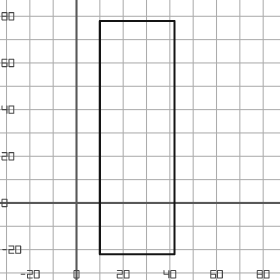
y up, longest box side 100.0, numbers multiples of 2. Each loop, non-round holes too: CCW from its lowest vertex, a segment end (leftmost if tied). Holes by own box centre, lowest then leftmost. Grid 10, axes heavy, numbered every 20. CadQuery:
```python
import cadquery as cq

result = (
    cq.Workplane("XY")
    .moveTo(10.0, -22.0)
    .lineTo(42.0, -22.0)
    .lineTo(42.0, 78.0)
    .lineTo(10.0, 78.0)
    .close()
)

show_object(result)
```